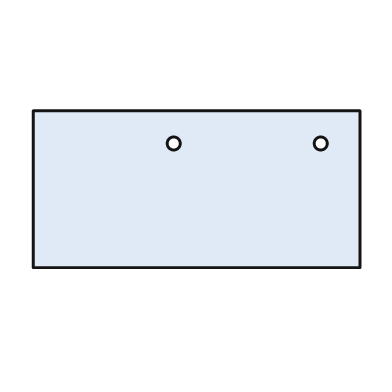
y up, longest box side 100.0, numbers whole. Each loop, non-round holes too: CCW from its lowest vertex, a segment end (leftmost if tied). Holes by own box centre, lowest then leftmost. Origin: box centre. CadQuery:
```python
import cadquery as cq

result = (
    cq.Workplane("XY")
    .moveTo(-50.0, -24.0)
    .lineTo(50.0, -24.0)
    .lineTo(50.0, 24.0)
    .lineTo(-50.0, 24.0)
    .close()
    .moveTo(-7.0, 14.0)
    .circle(2.0)
    .moveTo(38.0, 14.0)
    .circle(2.0)
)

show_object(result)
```